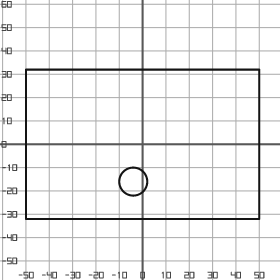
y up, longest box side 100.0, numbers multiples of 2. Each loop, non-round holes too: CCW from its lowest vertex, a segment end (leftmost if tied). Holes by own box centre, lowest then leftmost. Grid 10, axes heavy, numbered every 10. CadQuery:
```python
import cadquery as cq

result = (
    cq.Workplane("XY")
    .moveTo(-50.0, -32.0)
    .lineTo(50.0, -32.0)
    .lineTo(50.0, 32.0)
    .lineTo(-50.0, 32.0)
    .close()
    .moveTo(-4.0, -16.0)
    .circle(6.0)
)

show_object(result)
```